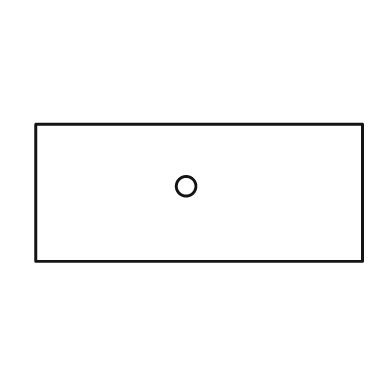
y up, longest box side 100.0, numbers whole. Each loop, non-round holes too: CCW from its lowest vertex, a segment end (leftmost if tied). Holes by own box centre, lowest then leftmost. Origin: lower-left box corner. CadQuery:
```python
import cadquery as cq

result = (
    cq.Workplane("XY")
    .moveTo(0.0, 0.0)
    .lineTo(100.0, 0.0)
    .lineTo(100.0, 42.0)
    .lineTo(0.0, 42.0)
    .close()
    .moveTo(46.0, 23.0)
    .circle(3.0)
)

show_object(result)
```